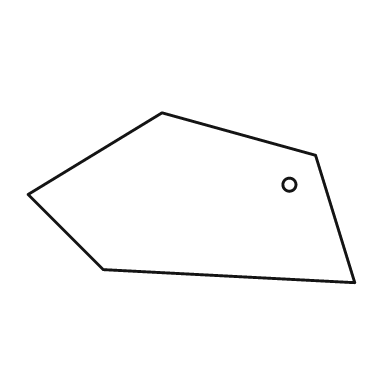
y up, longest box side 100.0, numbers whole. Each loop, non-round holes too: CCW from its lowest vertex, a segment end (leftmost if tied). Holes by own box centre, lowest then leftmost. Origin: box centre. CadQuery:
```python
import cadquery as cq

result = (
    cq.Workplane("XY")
    .moveTo(50.0, -26.0)
    .lineTo(38.0, 13.0)
    .lineTo(-9.0, 26.0)
    .lineTo(-50.0, 1.0)
    .lineTo(-27.0, -22.0)
    .close()
    .moveTo(30.0, 4.0)
    .circle(2.0)
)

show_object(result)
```